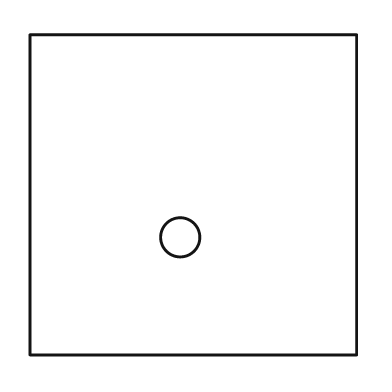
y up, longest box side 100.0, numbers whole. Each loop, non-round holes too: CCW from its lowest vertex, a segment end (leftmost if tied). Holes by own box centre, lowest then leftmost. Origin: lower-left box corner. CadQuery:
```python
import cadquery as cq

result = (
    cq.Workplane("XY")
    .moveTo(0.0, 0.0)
    .lineTo(100.0, 0.0)
    .lineTo(100.0, 98.0)
    .lineTo(0.0, 98.0)
    .close()
    .moveTo(46.0, 36.0)
    .circle(6.0)
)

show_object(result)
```